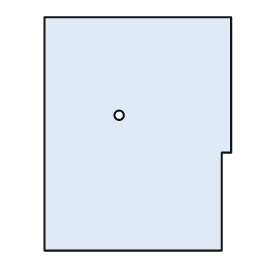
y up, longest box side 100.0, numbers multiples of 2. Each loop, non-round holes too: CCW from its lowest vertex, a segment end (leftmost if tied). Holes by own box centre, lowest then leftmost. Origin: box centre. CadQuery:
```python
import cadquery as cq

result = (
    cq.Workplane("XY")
    .moveTo(-40.0, -50.0)
    .lineTo(36.0, -50.0)
    .lineTo(36.0, -8.0)
    .lineTo(40.0, -8.0)
    .lineTo(40.0, 50.0)
    .lineTo(-40.0, 50.0)
    .close()
    .moveTo(-8.0, 8.0)
    .circle(2.0)
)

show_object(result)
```